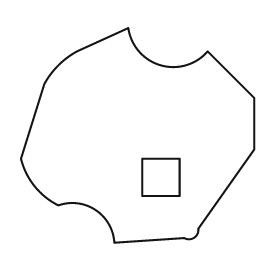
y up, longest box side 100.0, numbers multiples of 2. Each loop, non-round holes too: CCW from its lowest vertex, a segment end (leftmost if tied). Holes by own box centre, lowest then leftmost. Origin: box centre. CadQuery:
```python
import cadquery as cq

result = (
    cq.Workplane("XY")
    .moveTo(-10.0, -46.0)
    .lineTo(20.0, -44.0)
    .threePointArc((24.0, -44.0), (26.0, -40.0))
    .lineTo(50.0, -6.0)
    .lineTo(50.0, 16.0)
    .lineTo(30.0, 36.0)
    .threePointArc((10.0, 30.0), (-4.0, 46.0))
    .lineTo(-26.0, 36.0)
    .threePointArc((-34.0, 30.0), (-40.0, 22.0))
    .lineTo(-50.0, -10.0)
    .threePointArc((-44.0, -22.0), (-34.0, -30.0))
    .threePointArc((-18.0, -32.0), (-10.0, -46.0))
    .close()
    .moveTo(2.0, -26.0)
    .lineTo(18.0, -26.0)
    .lineTo(18.0, -10.0)
    .lineTo(2.0, -10.0)
    .close()
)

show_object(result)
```